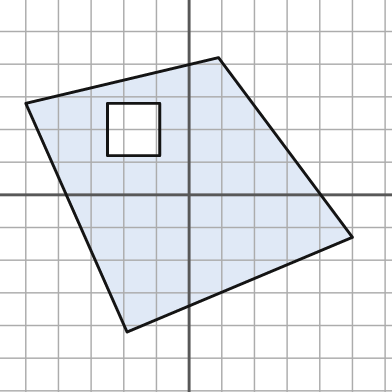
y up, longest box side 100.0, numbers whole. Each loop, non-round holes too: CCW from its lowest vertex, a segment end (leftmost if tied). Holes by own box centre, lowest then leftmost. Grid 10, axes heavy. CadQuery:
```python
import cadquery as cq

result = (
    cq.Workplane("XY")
    .moveTo(-19.0, -42.0)
    .lineTo(50.0, -13.0)
    .lineTo(9.0, 42.0)
    .lineTo(-50.0, 28.0)
    .close()
    .moveTo(-25.0, 12.0)
    .lineTo(-9.0, 12.0)
    .lineTo(-9.0, 28.0)
    .lineTo(-25.0, 28.0)
    .close()
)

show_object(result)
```